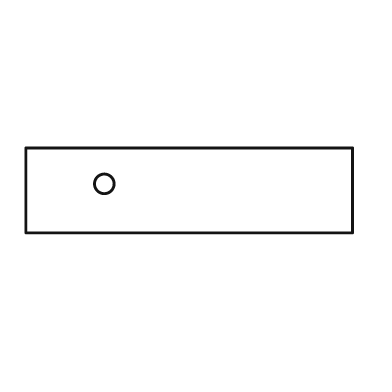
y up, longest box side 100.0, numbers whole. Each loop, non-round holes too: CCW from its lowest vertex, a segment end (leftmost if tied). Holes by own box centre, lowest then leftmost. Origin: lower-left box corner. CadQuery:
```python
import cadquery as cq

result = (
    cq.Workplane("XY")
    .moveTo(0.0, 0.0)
    .lineTo(100.0, 0.0)
    .lineTo(100.0, 26.0)
    .lineTo(0.0, 26.0)
    .close()
    .moveTo(24.0, 15.0)
    .circle(3.0)
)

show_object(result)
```